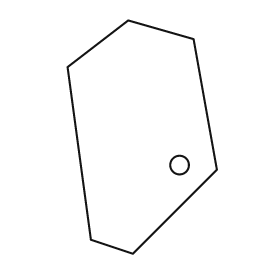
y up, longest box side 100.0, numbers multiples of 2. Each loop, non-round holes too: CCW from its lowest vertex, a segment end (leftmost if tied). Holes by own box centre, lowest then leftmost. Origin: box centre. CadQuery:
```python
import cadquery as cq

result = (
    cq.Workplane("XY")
    .moveTo(-4.0, -50.0)
    .lineTo(32.0, -14.0)
    .lineTo(22.0, 42.0)
    .lineTo(-6.0, 50.0)
    .lineTo(-32.0, 30.0)
    .lineTo(-22.0, -44.0)
    .close()
    .moveTo(16.0, -12.0)
    .circle(4.0)
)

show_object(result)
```